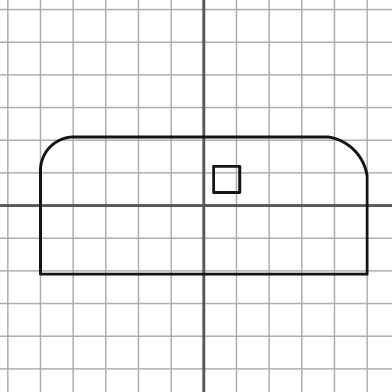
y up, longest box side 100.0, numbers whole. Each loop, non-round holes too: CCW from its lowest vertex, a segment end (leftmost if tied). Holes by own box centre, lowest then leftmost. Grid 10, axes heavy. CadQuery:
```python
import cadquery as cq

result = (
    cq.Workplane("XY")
    .moveTo(-50.0, -21.0)
    .lineTo(50.0, -21.0)
    .lineTo(50.0, 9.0)
    .threePointArc((46.0, 17.0), (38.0, 21.0))
    .lineTo(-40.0, 21.0)
    .threePointArc((-47.0, 18.0), (-50.0, 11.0))
    .close()
    .moveTo(3.0, 4.0)
    .lineTo(11.0, 4.0)
    .lineTo(11.0, 12.0)
    .lineTo(3.0, 12.0)
    .close()
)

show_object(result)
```